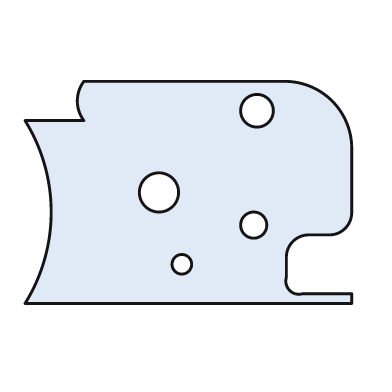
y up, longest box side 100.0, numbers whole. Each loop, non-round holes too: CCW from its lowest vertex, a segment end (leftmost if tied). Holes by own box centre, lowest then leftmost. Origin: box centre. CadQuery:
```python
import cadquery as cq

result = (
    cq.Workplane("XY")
    .moveTo(-50.0, -34.0)
    .lineTo(50.0, -34.0)
    .lineTo(50.0, -31.0)
    .lineTo(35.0, -31.0)
    .threePointArc((31.0, -30.0), (30.0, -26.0))
    .lineTo(30.0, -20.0)
    .threePointArc((32.0, -15.0), (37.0, -13.0))
    .lineTo(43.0, -13.0)
    .threePointArc((48.0, -11.0), (50.0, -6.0))
    .lineTo(50.0, 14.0)
    .threePointArc((44.0, 28.0), (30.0, 34.0))
    .lineTo(-32.0, 34.0)
    .threePointArc((-34.0, 28.0), (-32.0, 22.0))
    .lineTo(-50.0, 22.0)
    .threePointArc((-42.0, -6.0), (-50.0, -34.0))
    .close()
    .moveTo(-2.0, -22.0)
    .circle(3.0)
    .moveTo(20.0, -10.0)
    .circle(4.0)
    .moveTo(-9.0, 0.0)
    .circle(6.0)
    .moveTo(21.0, 25.0)
    .circle(5.0)
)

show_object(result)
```